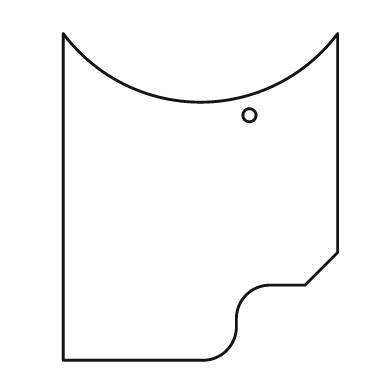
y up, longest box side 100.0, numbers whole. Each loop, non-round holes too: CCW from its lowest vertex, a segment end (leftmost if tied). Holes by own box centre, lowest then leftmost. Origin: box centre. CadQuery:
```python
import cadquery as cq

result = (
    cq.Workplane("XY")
    .moveTo(-42.0, -50.0)
    .lineTo(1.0, -50.0)
    .threePointArc((8.0, -47.0), (11.0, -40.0))
    .lineTo(11.0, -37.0)
    .threePointArc((14.0, -30.0), (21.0, -27.0))
    .lineTo(32.0, -27.0)
    .lineTo(42.0, -17.0)
    .lineTo(42.0, 50.0)
    .threePointArc((0.0, 29.0), (-42.0, 50.0))
    .close()
    .moveTo(15.0, 25.0)
    .circle(2.0)
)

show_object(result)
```